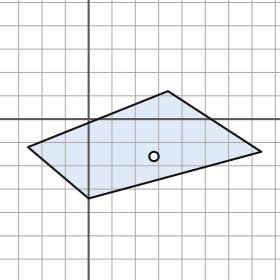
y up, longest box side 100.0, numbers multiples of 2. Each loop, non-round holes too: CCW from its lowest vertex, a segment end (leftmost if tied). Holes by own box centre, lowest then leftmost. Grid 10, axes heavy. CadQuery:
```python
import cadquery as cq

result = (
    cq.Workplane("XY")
    .moveTo(0.0, -34.0)
    .lineTo(74.0, -14.0)
    .lineTo(34.0, 12.0)
    .lineTo(-26.0, -12.0)
    .close()
    .moveTo(28.0, -16.0)
    .circle(2.0)
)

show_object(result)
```